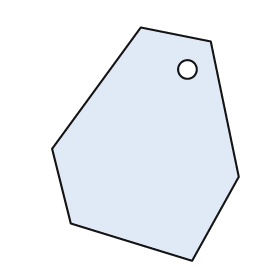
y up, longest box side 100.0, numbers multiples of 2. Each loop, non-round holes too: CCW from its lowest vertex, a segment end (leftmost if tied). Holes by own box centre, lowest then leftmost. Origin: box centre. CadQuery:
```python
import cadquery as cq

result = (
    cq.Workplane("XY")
    .moveTo(20.0, -50.0)
    .lineTo(40.0, -14.0)
    .lineTo(28.0, 44.0)
    .lineTo(-2.0, 50.0)
    .lineTo(-40.0, -2.0)
    .lineTo(-32.0, -34.0)
    .close()
    .moveTo(18.0, 32.0)
    .circle(4.0)
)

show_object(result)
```